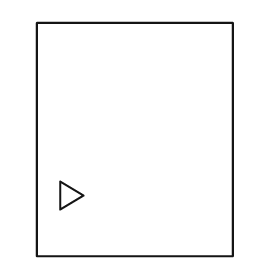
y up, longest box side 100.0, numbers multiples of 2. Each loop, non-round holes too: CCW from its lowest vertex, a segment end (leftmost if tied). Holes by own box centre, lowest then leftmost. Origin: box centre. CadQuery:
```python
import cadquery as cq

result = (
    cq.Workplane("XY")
    .moveTo(-42.0, -50.0)
    .lineTo(42.0, -50.0)
    .lineTo(42.0, 50.0)
    .lineTo(-42.0, 50.0)
    .close()
    .moveTo(-32.0, -30.0)
    .lineTo(-22.0, -24.0)
    .lineTo(-32.0, -18.0)
    .close()
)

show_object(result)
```